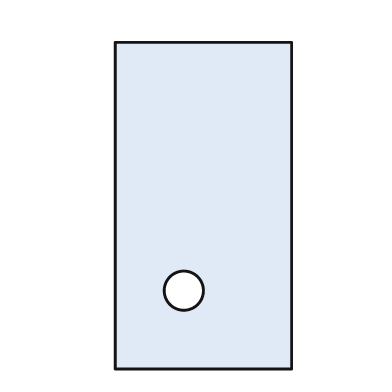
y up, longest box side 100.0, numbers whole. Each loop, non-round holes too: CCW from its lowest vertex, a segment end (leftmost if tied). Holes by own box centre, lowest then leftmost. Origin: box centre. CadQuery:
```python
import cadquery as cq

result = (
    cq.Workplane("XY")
    .moveTo(-27.0, -50.0)
    .lineTo(27.0, -50.0)
    .lineTo(27.0, 50.0)
    .lineTo(-27.0, 50.0)
    .close()
    .moveTo(-6.0, -26.0)
    .circle(6.0)
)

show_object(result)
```